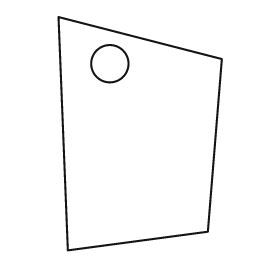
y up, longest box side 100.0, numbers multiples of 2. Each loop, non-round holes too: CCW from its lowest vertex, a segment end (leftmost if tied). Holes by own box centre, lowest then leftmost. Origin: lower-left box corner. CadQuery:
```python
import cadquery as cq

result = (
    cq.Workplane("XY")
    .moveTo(4.0, 0.0)
    .lineTo(64.0, 8.0)
    .lineTo(70.0, 82.0)
    .lineTo(0.0, 100.0)
    .close()
    .moveTo(22.0, 80.0)
    .circle(8.0)
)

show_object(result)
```